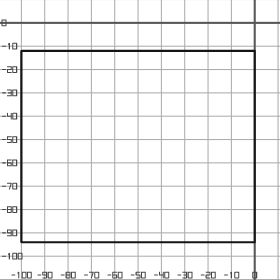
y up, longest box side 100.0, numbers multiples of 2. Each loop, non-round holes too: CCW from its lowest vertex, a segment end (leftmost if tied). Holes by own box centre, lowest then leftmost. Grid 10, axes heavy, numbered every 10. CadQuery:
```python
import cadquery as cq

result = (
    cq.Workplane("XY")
    .moveTo(-100.0, -94.0)
    .lineTo(0.0, -94.0)
    .lineTo(0.0, -12.0)
    .lineTo(-100.0, -12.0)
    .close()
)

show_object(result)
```